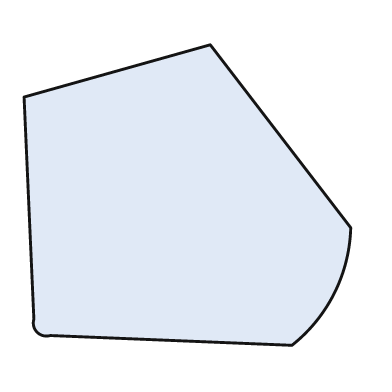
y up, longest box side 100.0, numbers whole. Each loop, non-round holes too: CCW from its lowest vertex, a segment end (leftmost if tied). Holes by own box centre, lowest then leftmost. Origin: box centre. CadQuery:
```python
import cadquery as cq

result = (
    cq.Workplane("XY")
    .moveTo(32.0, -46.0)
    .threePointArc((45.0, -30.0), (50.0, -10.0))
    .lineTo(7.0, 46.0)
    .lineTo(-50.0, 30.0)
    .lineTo(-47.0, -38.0)
    .threePointArc((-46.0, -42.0), (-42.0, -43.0))
    .close()
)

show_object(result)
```